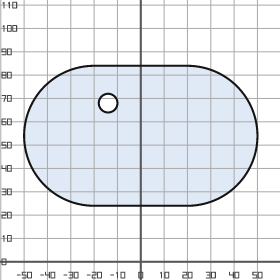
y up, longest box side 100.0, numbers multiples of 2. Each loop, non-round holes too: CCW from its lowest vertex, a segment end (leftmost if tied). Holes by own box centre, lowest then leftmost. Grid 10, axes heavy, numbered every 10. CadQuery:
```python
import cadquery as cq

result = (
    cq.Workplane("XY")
    .moveTo(-20.0, 24.0)
    .lineTo(20.0, 24.0)
    .threePointArc((50.0, 54.0), (20.0, 84.0))
    .lineTo(-20.0, 84.0)
    .threePointArc((-50.0, 54.0), (-20.0, 24.0))
    .close()
    .moveTo(-14.0, 68.0)
    .circle(4.0)
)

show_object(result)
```